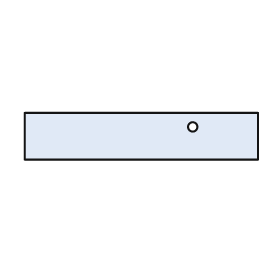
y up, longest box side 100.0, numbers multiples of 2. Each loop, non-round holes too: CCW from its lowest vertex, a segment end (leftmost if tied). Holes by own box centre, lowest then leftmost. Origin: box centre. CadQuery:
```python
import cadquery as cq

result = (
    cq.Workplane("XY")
    .moveTo(-50.0, -10.0)
    .lineTo(50.0, -10.0)
    .lineTo(50.0, 10.0)
    .lineTo(-50.0, 10.0)
    .close()
    .moveTo(22.0, 4.0)
    .circle(2.0)
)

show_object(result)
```